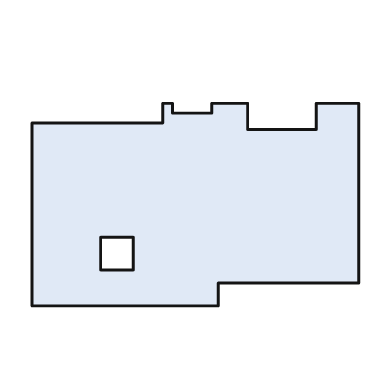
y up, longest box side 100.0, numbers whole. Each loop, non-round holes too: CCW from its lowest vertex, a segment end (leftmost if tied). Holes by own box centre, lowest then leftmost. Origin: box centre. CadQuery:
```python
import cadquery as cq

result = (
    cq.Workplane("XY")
    .moveTo(-50.0, -31.0)
    .lineTo(7.0, -31.0)
    .lineTo(7.0, -24.0)
    .lineTo(50.0, -24.0)
    .lineTo(50.0, 31.0)
    .lineTo(37.0, 31.0)
    .lineTo(37.0, 23.0)
    .lineTo(16.0, 23.0)
    .lineTo(16.0, 31.0)
    .lineTo(5.0, 31.0)
    .lineTo(5.0, 28.0)
    .lineTo(-7.0, 28.0)
    .lineTo(-7.0, 31.0)
    .lineTo(-10.0, 31.0)
    .lineTo(-10.0, 25.0)
    .lineTo(-50.0, 25.0)
    .close()
    .moveTo(-29.0, -20.0)
    .lineTo(-19.0, -20.0)
    .lineTo(-19.0, -10.0)
    .lineTo(-29.0, -10.0)
    .close()
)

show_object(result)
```